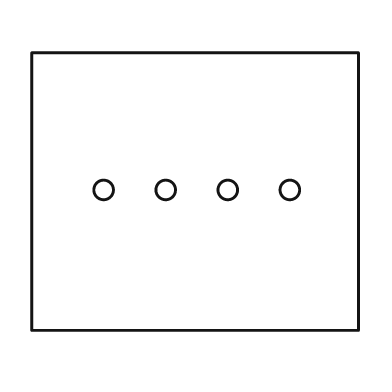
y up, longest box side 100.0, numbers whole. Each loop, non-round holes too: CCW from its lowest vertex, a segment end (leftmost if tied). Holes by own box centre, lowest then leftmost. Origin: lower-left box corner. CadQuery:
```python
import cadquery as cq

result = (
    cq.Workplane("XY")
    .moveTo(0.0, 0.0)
    .lineTo(100.0, 0.0)
    .lineTo(100.0, 85.0)
    .lineTo(0.0, 85.0)
    .close()
    .moveTo(22.0, 43.0)
    .circle(3.0)
    .moveTo(41.0, 43.0)
    .circle(3.0)
    .moveTo(60.0, 43.0)
    .circle(3.0)
    .moveTo(79.0, 43.0)
    .circle(3.0)
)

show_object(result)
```